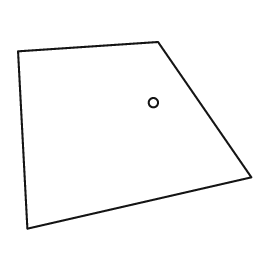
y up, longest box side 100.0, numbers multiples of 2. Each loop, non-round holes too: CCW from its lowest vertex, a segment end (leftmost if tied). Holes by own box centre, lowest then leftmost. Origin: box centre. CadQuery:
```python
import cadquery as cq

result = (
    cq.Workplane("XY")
    .moveTo(-46.0, -40.0)
    .lineTo(50.0, -18.0)
    .lineTo(10.0, 40.0)
    .lineTo(-50.0, 36.0)
    .close()
    .moveTo(8.0, 14.0)
    .circle(2.0)
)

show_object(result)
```